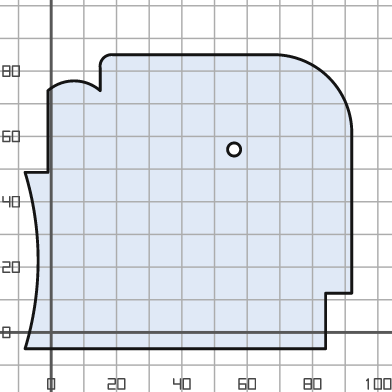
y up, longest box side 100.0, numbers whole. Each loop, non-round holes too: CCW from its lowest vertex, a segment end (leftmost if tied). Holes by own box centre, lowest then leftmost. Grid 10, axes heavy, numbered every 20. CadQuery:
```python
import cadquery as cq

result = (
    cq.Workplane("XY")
    .moveTo(-8.0, -5.0)
    .lineTo(84.0, -5.0)
    .lineTo(84.0, 12.0)
    .lineTo(92.0, 12.0)
    .lineTo(92.0, 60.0)
    .threePointArc((85.0, 78.0), (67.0, 85.0))
    .lineTo(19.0, 85.0)
    .threePointArc((16.0, 84.0), (15.0, 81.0))
    .lineTo(15.0, 74.0)
    .threePointArc((7.0, 77.0), (-1.0, 74.0))
    .lineTo(-1.0, 49.0)
    .lineTo(-8.0, 49.0)
    .threePointArc((-4.0, 22.0), (-8.0, -5.0))
    .close()
    .moveTo(56.0, 56.0)
    .circle(2.0)
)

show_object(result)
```